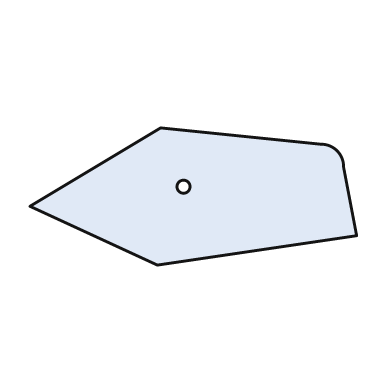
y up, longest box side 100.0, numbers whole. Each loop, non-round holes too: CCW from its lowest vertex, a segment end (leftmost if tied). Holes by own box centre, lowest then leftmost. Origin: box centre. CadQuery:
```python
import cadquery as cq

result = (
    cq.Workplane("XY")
    .moveTo(-11.0, -21.0)
    .lineTo(50.0, -12.0)
    .lineTo(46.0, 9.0)
    .threePointArc((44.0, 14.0), (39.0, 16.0))
    .lineTo(-10.0, 21.0)
    .lineTo(-50.0, -3.0)
    .close()
    .moveTo(-3.0, 3.0)
    .circle(2.0)
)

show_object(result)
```